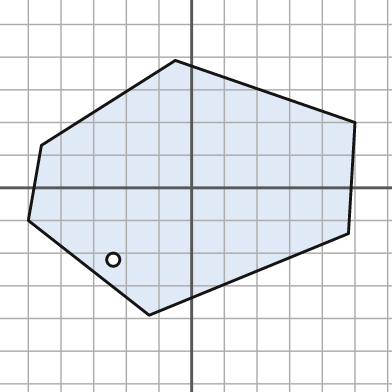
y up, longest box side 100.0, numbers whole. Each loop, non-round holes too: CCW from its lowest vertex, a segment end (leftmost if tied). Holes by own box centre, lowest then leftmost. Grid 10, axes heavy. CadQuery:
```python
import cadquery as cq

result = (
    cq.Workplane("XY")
    .moveTo(-13.0, -39.0)
    .lineTo(48.0, -14.0)
    .lineTo(50.0, 20.0)
    .lineTo(-5.0, 39.0)
    .lineTo(-46.0, 13.0)
    .lineTo(-50.0, -10.0)
    .close()
    .moveTo(-24.0, -22.0)
    .circle(2.0)
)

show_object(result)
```